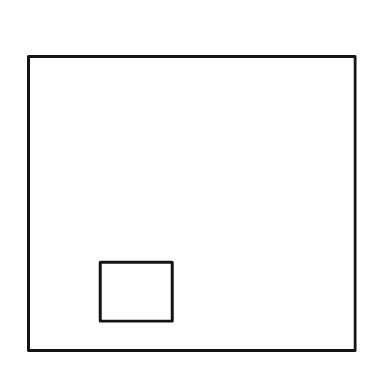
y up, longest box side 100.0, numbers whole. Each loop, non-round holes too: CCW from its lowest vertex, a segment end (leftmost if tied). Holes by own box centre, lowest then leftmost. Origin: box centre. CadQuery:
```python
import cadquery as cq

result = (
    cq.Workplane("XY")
    .moveTo(-50.0, -45.0)
    .lineTo(50.0, -45.0)
    .lineTo(50.0, 45.0)
    .lineTo(-50.0, 45.0)
    .close()
    .moveTo(-28.0, -36.0)
    .lineTo(-6.0, -36.0)
    .lineTo(-6.0, -18.0)
    .lineTo(-28.0, -18.0)
    .close()
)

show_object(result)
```